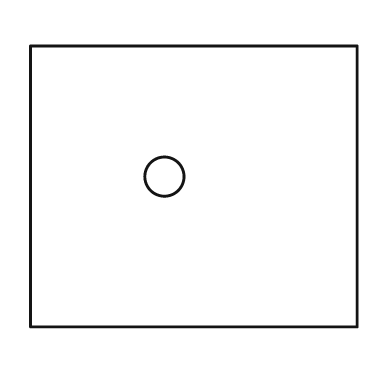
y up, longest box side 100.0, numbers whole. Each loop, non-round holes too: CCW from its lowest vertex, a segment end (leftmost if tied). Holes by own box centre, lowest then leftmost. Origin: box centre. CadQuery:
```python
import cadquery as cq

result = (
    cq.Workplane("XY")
    .moveTo(-50.0, -43.0)
    .lineTo(50.0, -43.0)
    .lineTo(50.0, 43.0)
    .lineTo(-50.0, 43.0)
    .close()
    .moveTo(-9.0, 3.0)
    .circle(6.0)
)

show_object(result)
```